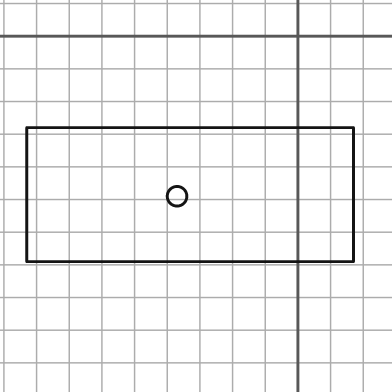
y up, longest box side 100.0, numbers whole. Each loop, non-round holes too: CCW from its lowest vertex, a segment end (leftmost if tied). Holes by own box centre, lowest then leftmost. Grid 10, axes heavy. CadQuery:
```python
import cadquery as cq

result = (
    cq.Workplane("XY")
    .moveTo(-83.0, -69.0)
    .lineTo(17.0, -69.0)
    .lineTo(17.0, -28.0)
    .lineTo(-83.0, -28.0)
    .close()
    .moveTo(-37.0, -49.0)
    .circle(3.0)
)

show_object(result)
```